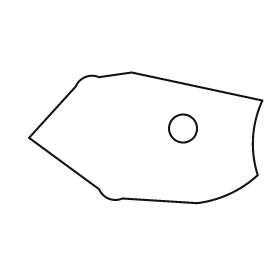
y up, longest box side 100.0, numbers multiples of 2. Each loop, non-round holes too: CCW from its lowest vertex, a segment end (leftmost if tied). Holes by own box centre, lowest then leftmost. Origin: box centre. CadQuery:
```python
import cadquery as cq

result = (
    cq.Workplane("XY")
    .moveTo(22.0, -28.0)
    .threePointArc((36.0, -24.0), (48.0, -16.0))
    .threePointArc((46.0, 0.0), (50.0, 16.0))
    .lineTo(-6.0, 28.0)
    .lineTo(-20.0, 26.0)
    .threePointArc((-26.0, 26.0), (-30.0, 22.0))
    .lineTo(-50.0, 0.0)
    .lineTo(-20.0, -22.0)
    .threePointArc((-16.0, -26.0), (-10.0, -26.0))
    .close()
    .moveTo(16.0, 4.0)
    .circle(6.0)
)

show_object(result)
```